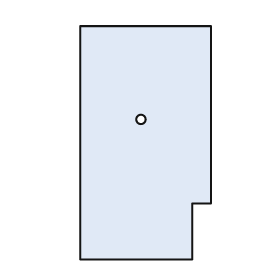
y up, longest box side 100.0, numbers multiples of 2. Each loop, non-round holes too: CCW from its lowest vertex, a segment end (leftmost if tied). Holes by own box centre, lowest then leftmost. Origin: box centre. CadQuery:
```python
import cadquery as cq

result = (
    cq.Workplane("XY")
    .moveTo(-28.0, -50.0)
    .lineTo(20.0, -50.0)
    .lineTo(20.0, -26.0)
    .lineTo(28.0, -26.0)
    .lineTo(28.0, 50.0)
    .lineTo(-28.0, 50.0)
    .close()
    .moveTo(-2.0, 10.0)
    .circle(2.0)
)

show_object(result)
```